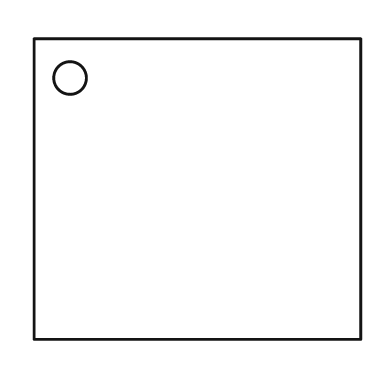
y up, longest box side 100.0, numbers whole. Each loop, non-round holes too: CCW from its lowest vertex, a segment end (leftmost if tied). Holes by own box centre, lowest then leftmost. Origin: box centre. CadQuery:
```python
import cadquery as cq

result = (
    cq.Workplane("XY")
    .moveTo(-50.0, -46.0)
    .lineTo(50.0, -46.0)
    .lineTo(50.0, 46.0)
    .lineTo(-50.0, 46.0)
    .close()
    .moveTo(-39.0, 34.0)
    .circle(5.0)
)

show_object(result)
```